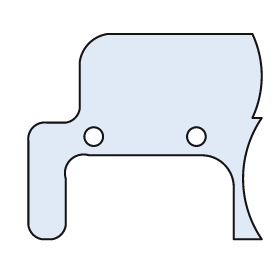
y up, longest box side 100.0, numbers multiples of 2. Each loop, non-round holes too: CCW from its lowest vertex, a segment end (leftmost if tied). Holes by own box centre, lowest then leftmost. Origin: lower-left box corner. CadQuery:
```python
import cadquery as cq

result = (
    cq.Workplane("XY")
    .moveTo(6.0, 0.0)
    .lineTo(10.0, 0.0)
    .threePointArc((14.0, 2.0), (16.0, 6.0))
    .lineTo(16.0, 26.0)
    .threePointArc((18.0, 34.0), (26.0, 36.0))
    .lineTo(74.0, 36.0)
    .threePointArc((84.0, 32.0), (88.0, 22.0))
    .lineTo(88.0, 0.0)
    .lineTo(100.0, 0.0)
    .threePointArc((92.0, 26.0), (100.0, 52.0))
    .lineTo(96.0, 52.0)
    .threePointArc((100.0, 70.0), (96.0, 88.0))
    .lineTo(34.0, 88.0)
    .threePointArc((26.0, 84.0), (22.0, 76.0))
    .lineTo(22.0, 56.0)
    .threePointArc((20.0, 52.0), (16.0, 50.0))
    .lineTo(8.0, 50.0)
    .threePointArc((2.0, 48.0), (0.0, 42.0))
    .lineTo(0.0, 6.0)
    .threePointArc((2.0, 2.0), (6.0, 0.0))
    .close()
    .moveTo(28.0, 44.0)
    .circle(4.0)
    .moveTo(72.0, 44.0)
    .circle(4.0)
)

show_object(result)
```